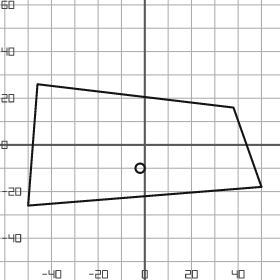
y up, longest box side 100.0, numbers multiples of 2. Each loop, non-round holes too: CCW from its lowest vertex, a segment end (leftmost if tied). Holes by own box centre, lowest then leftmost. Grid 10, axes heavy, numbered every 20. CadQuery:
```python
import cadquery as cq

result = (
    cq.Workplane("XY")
    .moveTo(-50.0, -26.0)
    .lineTo(50.0, -18.0)
    .lineTo(38.0, 16.0)
    .lineTo(-46.0, 26.0)
    .close()
    .moveTo(-2.0, -10.0)
    .circle(2.0)
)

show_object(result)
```